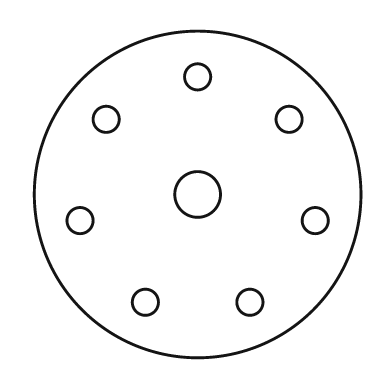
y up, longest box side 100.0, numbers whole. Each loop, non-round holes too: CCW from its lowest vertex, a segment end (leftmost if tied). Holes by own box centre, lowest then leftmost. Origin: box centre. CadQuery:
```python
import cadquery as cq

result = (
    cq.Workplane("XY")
    .moveTo(0.0, 0.0)
    .circle(50.0)
    .moveTo(-16.0, -33.0)
    .circle(4.0)
    .moveTo(16.0, -33.0)
    .circle(4.0)
    .moveTo(-36.0, -8.0)
    .circle(4.0)
    .moveTo(36.0, -8.0)
    .circle(4.0)
    .moveTo(0.0, 0.0)
    .circle(7.0)
    .moveTo(-28.0, 23.0)
    .circle(4.0)
    .moveTo(28.0, 23.0)
    .circle(4.0)
    .moveTo(0.0, 36.0)
    .circle(4.0)
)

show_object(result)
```